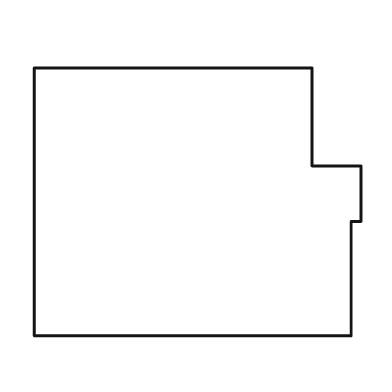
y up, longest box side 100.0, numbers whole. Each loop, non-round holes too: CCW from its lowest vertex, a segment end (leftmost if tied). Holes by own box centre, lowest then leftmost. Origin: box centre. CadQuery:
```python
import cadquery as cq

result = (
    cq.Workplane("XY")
    .moveTo(-50.0, -41.0)
    .lineTo(47.0, -41.0)
    .lineTo(47.0, -6.0)
    .lineTo(50.0, -6.0)
    .lineTo(50.0, 11.0)
    .lineTo(35.0, 11.0)
    .lineTo(35.0, 41.0)
    .lineTo(-50.0, 41.0)
    .close()
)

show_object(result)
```